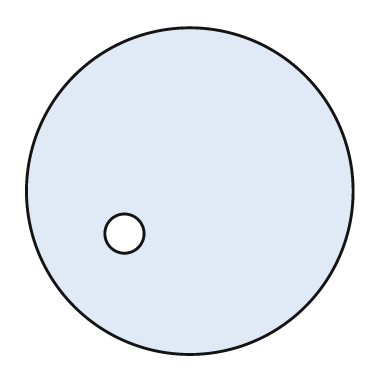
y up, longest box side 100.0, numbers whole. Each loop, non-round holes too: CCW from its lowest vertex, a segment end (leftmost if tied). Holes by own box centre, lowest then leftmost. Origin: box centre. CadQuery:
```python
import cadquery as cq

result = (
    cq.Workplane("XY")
    .moveTo(0.0, 0.0)
    .circle(50.0)
    .moveTo(-20.0, -13.0)
    .circle(6.0)
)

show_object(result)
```